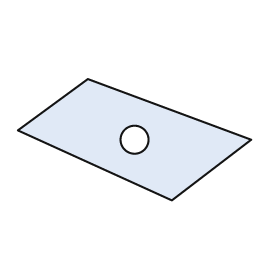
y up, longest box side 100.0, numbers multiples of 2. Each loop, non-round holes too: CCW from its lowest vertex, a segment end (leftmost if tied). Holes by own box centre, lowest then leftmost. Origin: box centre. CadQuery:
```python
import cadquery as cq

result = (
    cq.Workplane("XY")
    .moveTo(16.0, -26.0)
    .lineTo(50.0, 0.0)
    .lineTo(-20.0, 26.0)
    .lineTo(-50.0, 4.0)
    .close()
    .moveTo(0.0, 0.0)
    .circle(6.0)
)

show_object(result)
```